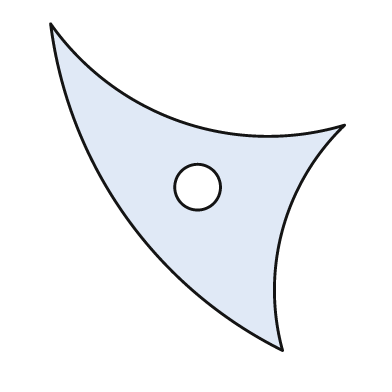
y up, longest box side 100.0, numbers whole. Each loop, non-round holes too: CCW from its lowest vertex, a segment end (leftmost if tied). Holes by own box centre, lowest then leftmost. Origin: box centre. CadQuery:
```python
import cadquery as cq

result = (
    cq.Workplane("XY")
    .moveTo(26.0, -50.0)
    .threePointArc((26.0, -13.0), (45.0, 19.0))
    .threePointArc((-5.0, 20.0), (-45.0, 50.0))
    .threePointArc((-22.0, -9.0), (26.0, -50.0))
    .close()
    .moveTo(0.0, 0.0)
    .circle(7.0)
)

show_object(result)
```